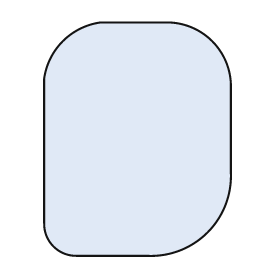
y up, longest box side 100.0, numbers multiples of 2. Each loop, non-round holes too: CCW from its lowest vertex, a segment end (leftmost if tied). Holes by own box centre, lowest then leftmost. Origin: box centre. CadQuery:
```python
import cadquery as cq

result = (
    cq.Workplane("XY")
    .moveTo(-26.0, -50.0)
    .lineTo(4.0, -50.0)
    .threePointArc((30.0, -40.0), (40.0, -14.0))
    .lineTo(40.0, 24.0)
    .threePointArc((32.0, 42.0), (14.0, 50.0))
    .lineTo(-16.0, 50.0)
    .threePointArc((-32.0, 42.0), (-40.0, 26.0))
    .lineTo(-40.0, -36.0)
    .threePointArc((-36.0, -46.0), (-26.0, -50.0))
    .close()
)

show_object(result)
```